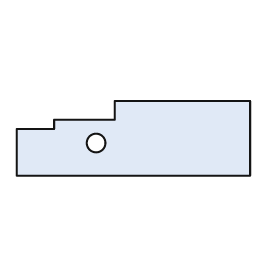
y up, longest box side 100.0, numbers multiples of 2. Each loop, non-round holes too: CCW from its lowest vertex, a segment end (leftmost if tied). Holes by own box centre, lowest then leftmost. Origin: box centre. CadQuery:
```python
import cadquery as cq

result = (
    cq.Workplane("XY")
    .moveTo(-50.0, -16.0)
    .lineTo(50.0, -16.0)
    .lineTo(50.0, 16.0)
    .lineTo(-8.0, 16.0)
    .lineTo(-8.0, 8.0)
    .lineTo(-34.0, 8.0)
    .lineTo(-34.0, 4.0)
    .lineTo(-50.0, 4.0)
    .close()
    .moveTo(-16.0, -2.0)
    .circle(4.0)
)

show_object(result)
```